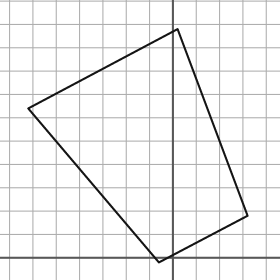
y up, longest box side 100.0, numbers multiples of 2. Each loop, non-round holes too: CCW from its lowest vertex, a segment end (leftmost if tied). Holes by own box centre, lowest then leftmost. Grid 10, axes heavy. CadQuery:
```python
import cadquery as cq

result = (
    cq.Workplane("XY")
    .moveTo(-6.0, -2.0)
    .lineTo(32.0, 18.0)
    .lineTo(2.0, 98.0)
    .lineTo(-62.0, 64.0)
    .close()
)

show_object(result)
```